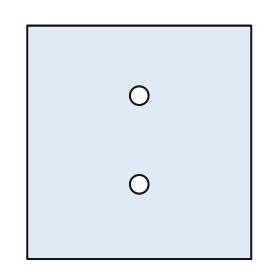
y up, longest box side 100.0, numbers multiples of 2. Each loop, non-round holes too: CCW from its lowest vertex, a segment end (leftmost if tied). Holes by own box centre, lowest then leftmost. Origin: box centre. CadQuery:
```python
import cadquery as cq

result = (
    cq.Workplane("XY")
    .moveTo(-48.0, -50.0)
    .lineTo(48.0, -50.0)
    .lineTo(48.0, 50.0)
    .lineTo(-48.0, 50.0)
    .close()
    .moveTo(0.0, -18.0)
    .circle(4.0)
    .moveTo(0.0, 20.0)
    .circle(4.0)
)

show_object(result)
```